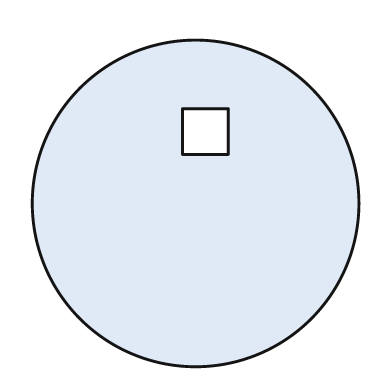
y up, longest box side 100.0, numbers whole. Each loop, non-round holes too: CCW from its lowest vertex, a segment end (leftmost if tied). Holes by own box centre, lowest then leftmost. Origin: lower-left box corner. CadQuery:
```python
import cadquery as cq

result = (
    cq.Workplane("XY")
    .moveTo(50.0, 50.0)
    .circle(50.0)
    .moveTo(46.0, 65.0)
    .lineTo(60.0, 65.0)
    .lineTo(60.0, 79.0)
    .lineTo(46.0, 79.0)
    .close()
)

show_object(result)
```